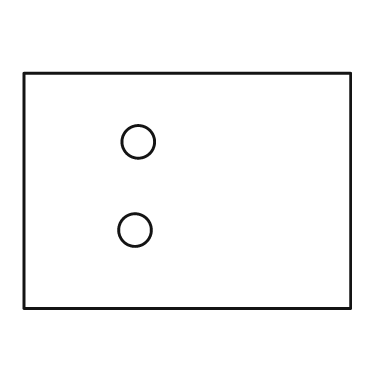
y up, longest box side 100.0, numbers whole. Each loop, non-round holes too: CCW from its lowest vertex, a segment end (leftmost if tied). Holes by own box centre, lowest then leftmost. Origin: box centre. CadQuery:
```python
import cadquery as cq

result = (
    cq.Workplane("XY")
    .moveTo(-50.0, -36.0)
    .lineTo(50.0, -36.0)
    .lineTo(50.0, 36.0)
    .lineTo(-50.0, 36.0)
    .close()
    .moveTo(-16.0, -12.0)
    .circle(5.0)
    .moveTo(-15.0, 15.0)
    .circle(5.0)
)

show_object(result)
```